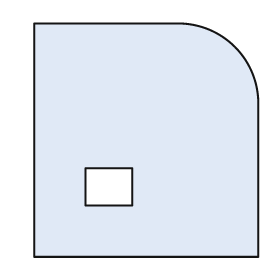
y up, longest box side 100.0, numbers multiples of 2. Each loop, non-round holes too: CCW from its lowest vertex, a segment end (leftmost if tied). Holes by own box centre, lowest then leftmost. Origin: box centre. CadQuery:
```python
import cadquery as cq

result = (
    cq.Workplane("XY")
    .moveTo(-48.0, -50.0)
    .lineTo(48.0, -50.0)
    .lineTo(48.0, 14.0)
    .threePointArc((38.0, 40.0), (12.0, 50.0))
    .lineTo(-48.0, 50.0)
    .close()
    .moveTo(-26.0, -28.0)
    .lineTo(-6.0, -28.0)
    .lineTo(-6.0, -12.0)
    .lineTo(-26.0, -12.0)
    .close()
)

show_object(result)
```